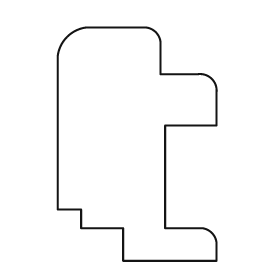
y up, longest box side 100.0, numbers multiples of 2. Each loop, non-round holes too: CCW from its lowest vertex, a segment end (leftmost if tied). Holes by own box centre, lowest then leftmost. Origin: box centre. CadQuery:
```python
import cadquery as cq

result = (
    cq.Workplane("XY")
    .moveTo(-6.0, -50.0)
    .lineTo(34.0, -50.0)
    .lineTo(34.0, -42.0)
    .threePointArc((32.0, -38.0), (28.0, -36.0))
    .lineTo(12.0, -36.0)
    .lineTo(12.0, 8.0)
    .lineTo(34.0, 8.0)
    .lineTo(34.0, 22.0)
    .threePointArc((32.0, 28.0), (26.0, 30.0))
    .lineTo(10.0, 30.0)
    .lineTo(10.0, 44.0)
    .threePointArc((8.0, 48.0), (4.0, 50.0))
    .lineTo(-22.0, 50.0)
    .threePointArc((-30.0, 46.0), (-34.0, 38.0))
    .lineTo(-34.0, -28.0)
    .lineTo(-24.0, -28.0)
    .lineTo(-24.0, -36.0)
    .lineTo(-6.0, -36.0)
    .close()
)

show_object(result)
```